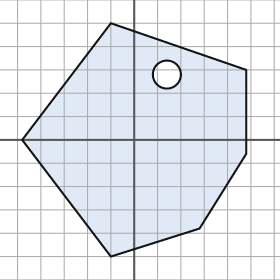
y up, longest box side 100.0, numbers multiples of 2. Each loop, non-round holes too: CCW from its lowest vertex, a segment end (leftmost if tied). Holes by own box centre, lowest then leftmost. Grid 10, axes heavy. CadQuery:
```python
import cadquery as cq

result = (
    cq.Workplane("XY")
    .moveTo(-10.0, -50.0)
    .lineTo(28.0, -38.0)
    .lineTo(48.0, -6.0)
    .lineTo(48.0, 30.0)
    .lineTo(-10.0, 50.0)
    .lineTo(-48.0, 0.0)
    .close()
    .moveTo(14.0, 28.0)
    .circle(6.0)
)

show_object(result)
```